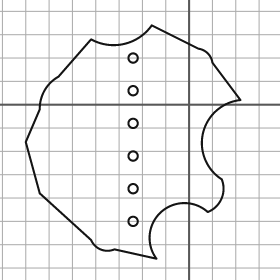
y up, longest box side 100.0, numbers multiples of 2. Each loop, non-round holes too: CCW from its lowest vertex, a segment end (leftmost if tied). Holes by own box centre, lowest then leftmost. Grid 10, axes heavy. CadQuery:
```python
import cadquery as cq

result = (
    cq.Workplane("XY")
    .moveTo(-14.0, -66.0)
    .threePointArc((-12.0, -46.0), (8.0, -46.0))
    .threePointArc((14.0, -40.0), (14.0, -32.0))
    .threePointArc((6.0, -12.0), (22.0, 2.0))
    .lineTo(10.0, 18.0)
    .threePointArc((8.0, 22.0), (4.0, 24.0))
    .lineTo(-16.0, 34.0)
    .threePointArc((-28.0, 26.0), (-42.0, 28.0))
    .lineTo(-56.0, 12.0)
    .threePointArc((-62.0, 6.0), (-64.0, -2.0))
    .lineTo(-70.0, -16.0)
    .lineTo(-64.0, -38.0)
    .lineTo(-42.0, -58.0)
    .threePointArc((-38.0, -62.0), (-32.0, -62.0))
    .close()
    .moveTo(-24.0, -50.0)
    .circle(2.0)
    .moveTo(-24.0, -36.0)
    .circle(2.0)
    .moveTo(-24.0, -22.0)
    .circle(2.0)
    .moveTo(-24.0, -8.0)
    .circle(2.0)
    .moveTo(-24.0, 6.0)
    .circle(2.0)
    .moveTo(-24.0, 20.0)
    .circle(2.0)
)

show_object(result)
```